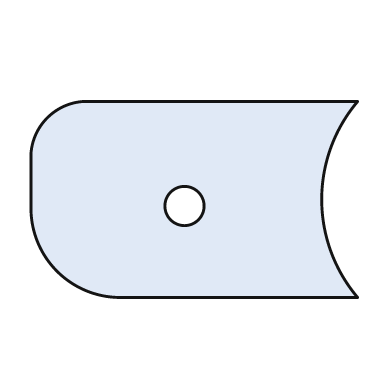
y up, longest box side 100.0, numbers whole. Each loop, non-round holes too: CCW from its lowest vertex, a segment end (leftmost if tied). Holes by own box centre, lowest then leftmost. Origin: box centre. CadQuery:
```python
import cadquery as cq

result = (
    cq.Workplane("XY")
    .moveTo(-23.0, -30.0)
    .lineTo(50.0, -30.0)
    .threePointArc((39.0, 0.0), (50.0, 30.0))
    .lineTo(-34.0, 30.0)
    .threePointArc((-45.0, 25.0), (-50.0, 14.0))
    .lineTo(-50.0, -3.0)
    .threePointArc((-42.0, -22.0), (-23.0, -30.0))
    .close()
    .moveTo(-3.0, -2.0)
    .circle(6.0)
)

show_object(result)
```